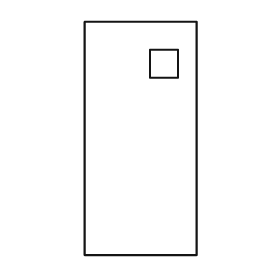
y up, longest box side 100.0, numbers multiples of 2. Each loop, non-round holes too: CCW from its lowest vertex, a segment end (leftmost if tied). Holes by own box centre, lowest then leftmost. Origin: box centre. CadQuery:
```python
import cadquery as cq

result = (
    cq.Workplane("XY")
    .moveTo(-24.0, -50.0)
    .lineTo(24.0, -50.0)
    .lineTo(24.0, 50.0)
    .lineTo(-24.0, 50.0)
    .close()
    .moveTo(4.0, 26.0)
    .lineTo(16.0, 26.0)
    .lineTo(16.0, 38.0)
    .lineTo(4.0, 38.0)
    .close()
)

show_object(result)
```